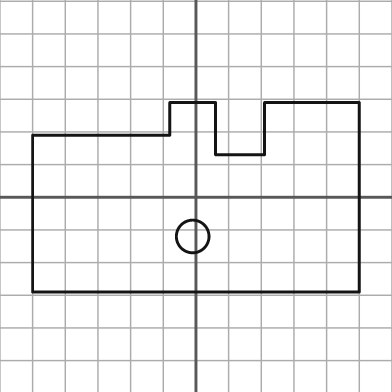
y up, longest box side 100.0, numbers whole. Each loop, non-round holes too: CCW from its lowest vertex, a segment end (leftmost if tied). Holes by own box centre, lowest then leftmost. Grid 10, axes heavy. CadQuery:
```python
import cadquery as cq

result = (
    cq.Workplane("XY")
    .moveTo(-50.0, -29.0)
    .lineTo(50.0, -29.0)
    .lineTo(50.0, 29.0)
    .lineTo(21.0, 29.0)
    .lineTo(21.0, 13.0)
    .lineTo(6.0, 13.0)
    .lineTo(6.0, 29.0)
    .lineTo(-8.0, 29.0)
    .lineTo(-8.0, 19.0)
    .lineTo(-50.0, 19.0)
    .close()
    .moveTo(-1.0, -12.0)
    .circle(5.0)
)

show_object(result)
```